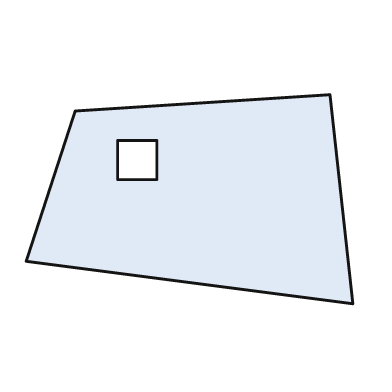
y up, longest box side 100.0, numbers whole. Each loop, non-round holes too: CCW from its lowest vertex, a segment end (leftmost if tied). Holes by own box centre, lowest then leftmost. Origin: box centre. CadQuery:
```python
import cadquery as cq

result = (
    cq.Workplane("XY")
    .moveTo(50.0, -32.0)
    .lineTo(43.0, 32.0)
    .lineTo(-35.0, 27.0)
    .lineTo(-50.0, -19.0)
    .close()
    .moveTo(-22.0, 6.0)
    .lineTo(-10.0, 6.0)
    .lineTo(-10.0, 18.0)
    .lineTo(-22.0, 18.0)
    .close()
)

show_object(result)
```